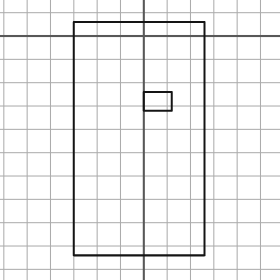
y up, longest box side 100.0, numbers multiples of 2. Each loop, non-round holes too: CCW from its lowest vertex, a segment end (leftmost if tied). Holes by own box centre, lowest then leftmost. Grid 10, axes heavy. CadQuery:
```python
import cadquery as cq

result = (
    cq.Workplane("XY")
    .moveTo(-30.0, -94.0)
    .lineTo(26.0, -94.0)
    .lineTo(26.0, 6.0)
    .lineTo(-30.0, 6.0)
    .close()
    .moveTo(0.0, -32.0)
    .lineTo(12.0, -32.0)
    .lineTo(12.0, -24.0)
    .lineTo(0.0, -24.0)
    .close()
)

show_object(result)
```